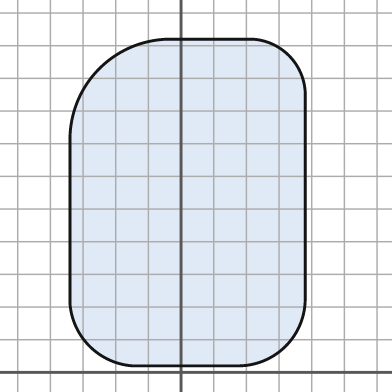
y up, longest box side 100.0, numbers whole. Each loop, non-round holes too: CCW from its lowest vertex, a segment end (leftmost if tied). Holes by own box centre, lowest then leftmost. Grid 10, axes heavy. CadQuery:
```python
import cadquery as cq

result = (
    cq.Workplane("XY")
    .moveTo(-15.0, 2.0)
    .lineTo(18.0, 2.0)
    .threePointArc((32.0, 8.0), (38.0, 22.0))
    .lineTo(38.0, 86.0)
    .threePointArc((33.0, 97.0), (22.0, 102.0))
    .lineTo(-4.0, 102.0)
    .threePointArc((-25.0, 93.0), (-34.0, 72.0))
    .lineTo(-34.0, 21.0)
    .threePointArc((-28.0, 8.0), (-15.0, 2.0))
    .close()
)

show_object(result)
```